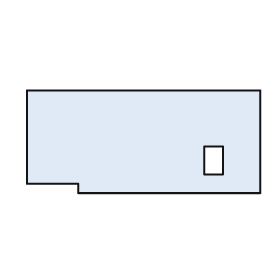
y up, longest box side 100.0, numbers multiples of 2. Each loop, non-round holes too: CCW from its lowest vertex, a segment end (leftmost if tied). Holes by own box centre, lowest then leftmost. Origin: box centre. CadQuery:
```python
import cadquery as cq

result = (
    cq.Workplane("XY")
    .moveTo(-28.0, -22.0)
    .lineTo(50.0, -22.0)
    .lineTo(50.0, 22.0)
    .lineTo(-50.0, 22.0)
    .lineTo(-50.0, -18.0)
    .lineTo(-28.0, -18.0)
    .close()
    .moveTo(26.0, -14.0)
    .lineTo(34.0, -14.0)
    .lineTo(34.0, -2.0)
    .lineTo(26.0, -2.0)
    .close()
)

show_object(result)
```